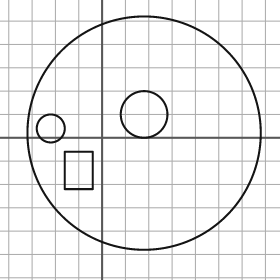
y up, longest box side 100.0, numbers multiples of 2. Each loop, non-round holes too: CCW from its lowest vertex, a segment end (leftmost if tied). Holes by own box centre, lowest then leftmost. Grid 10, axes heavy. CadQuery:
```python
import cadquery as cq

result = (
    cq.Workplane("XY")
    .moveTo(18.0, 2.0)
    .circle(50.0)
    .moveTo(-16.0, -22.0)
    .lineTo(-4.0, -22.0)
    .lineTo(-4.0, -6.0)
    .lineTo(-16.0, -6.0)
    .close()
    .moveTo(-22.0, 4.0)
    .circle(6.0)
    .moveTo(18.0, 10.0)
    .circle(10.0)
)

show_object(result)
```